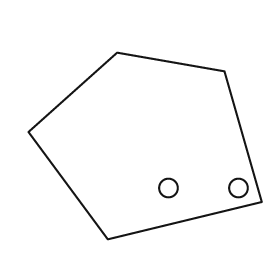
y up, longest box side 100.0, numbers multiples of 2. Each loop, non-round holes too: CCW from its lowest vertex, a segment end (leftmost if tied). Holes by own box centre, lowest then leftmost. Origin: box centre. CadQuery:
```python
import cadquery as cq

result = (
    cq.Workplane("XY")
    .moveTo(-16.0, -40.0)
    .lineTo(50.0, -24.0)
    .lineTo(34.0, 32.0)
    .lineTo(-12.0, 40.0)
    .lineTo(-50.0, 6.0)
    .close()
    .moveTo(10.0, -18.0)
    .circle(4.0)
    .moveTo(40.0, -18.0)
    .circle(4.0)
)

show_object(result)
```